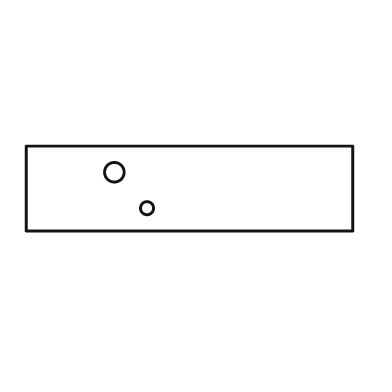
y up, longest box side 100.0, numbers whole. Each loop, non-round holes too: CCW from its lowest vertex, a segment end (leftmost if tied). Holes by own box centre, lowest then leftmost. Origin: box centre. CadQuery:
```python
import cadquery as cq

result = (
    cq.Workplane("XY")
    .moveTo(-50.0, -13.0)
    .lineTo(50.0, -13.0)
    .lineTo(50.0, 13.0)
    .lineTo(-50.0, 13.0)
    .close()
    .moveTo(-13.0, -6.0)
    .circle(2.0)
    .moveTo(-23.0, 5.0)
    .circle(3.0)
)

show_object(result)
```